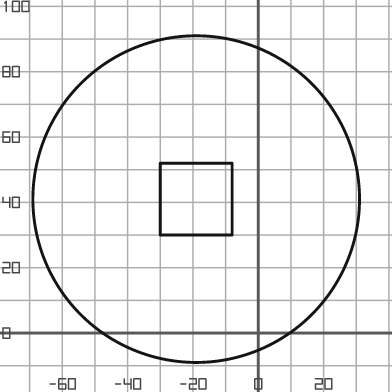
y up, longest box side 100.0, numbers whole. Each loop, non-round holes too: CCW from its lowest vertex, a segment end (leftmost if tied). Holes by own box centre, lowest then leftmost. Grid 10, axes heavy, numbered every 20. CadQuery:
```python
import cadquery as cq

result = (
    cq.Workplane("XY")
    .moveTo(-19.0, 41.0)
    .circle(50.0)
    .moveTo(-30.0, 30.0)
    .lineTo(-8.0, 30.0)
    .lineTo(-8.0, 52.0)
    .lineTo(-30.0, 52.0)
    .close()
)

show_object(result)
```